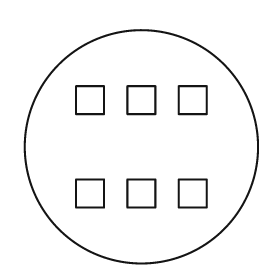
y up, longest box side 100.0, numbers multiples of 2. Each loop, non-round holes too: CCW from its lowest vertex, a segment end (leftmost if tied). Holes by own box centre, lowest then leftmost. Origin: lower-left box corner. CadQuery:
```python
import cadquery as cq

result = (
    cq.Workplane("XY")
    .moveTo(50.0, 50.0)
    .circle(50.0)
    .moveTo(22.0, 24.0)
    .lineTo(34.0, 24.0)
    .lineTo(34.0, 36.0)
    .lineTo(22.0, 36.0)
    .close()
    .moveTo(44.0, 24.0)
    .lineTo(56.0, 24.0)
    .lineTo(56.0, 36.0)
    .lineTo(44.0, 36.0)
    .close()
    .moveTo(66.0, 24.0)
    .lineTo(78.0, 24.0)
    .lineTo(78.0, 36.0)
    .lineTo(66.0, 36.0)
    .close()
    .moveTo(22.0, 64.0)
    .lineTo(34.0, 64.0)
    .lineTo(34.0, 76.0)
    .lineTo(22.0, 76.0)
    .close()
    .moveTo(44.0, 64.0)
    .lineTo(56.0, 64.0)
    .lineTo(56.0, 76.0)
    .lineTo(44.0, 76.0)
    .close()
    .moveTo(66.0, 64.0)
    .lineTo(78.0, 64.0)
    .lineTo(78.0, 76.0)
    .lineTo(66.0, 76.0)
    .close()
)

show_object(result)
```